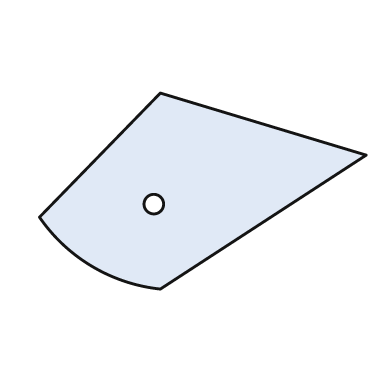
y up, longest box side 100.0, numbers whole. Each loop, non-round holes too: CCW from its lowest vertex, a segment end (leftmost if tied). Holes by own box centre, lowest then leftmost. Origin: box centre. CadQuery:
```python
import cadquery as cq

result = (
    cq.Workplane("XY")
    .moveTo(-13.0, -30.0)
    .lineTo(50.0, 11.0)
    .lineTo(-13.0, 30.0)
    .lineTo(-50.0, -8.0)
    .threePointArc((-34.0, -23.0), (-13.0, -30.0))
    .close()
    .moveTo(-15.0, -4.0)
    .circle(3.0)
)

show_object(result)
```